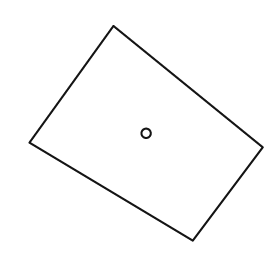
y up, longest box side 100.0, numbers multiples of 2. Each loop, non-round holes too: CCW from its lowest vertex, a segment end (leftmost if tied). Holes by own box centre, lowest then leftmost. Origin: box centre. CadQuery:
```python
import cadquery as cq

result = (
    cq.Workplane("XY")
    .moveTo(20.0, -46.0)
    .lineTo(50.0, -6.0)
    .lineTo(-14.0, 46.0)
    .lineTo(-50.0, -4.0)
    .close()
    .moveTo(0.0, 0.0)
    .circle(2.0)
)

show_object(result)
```